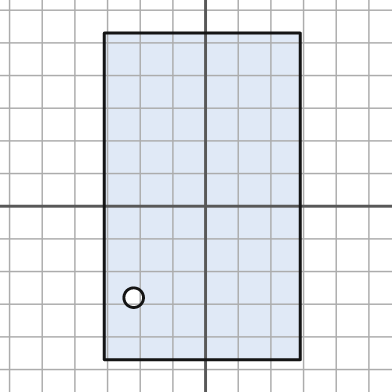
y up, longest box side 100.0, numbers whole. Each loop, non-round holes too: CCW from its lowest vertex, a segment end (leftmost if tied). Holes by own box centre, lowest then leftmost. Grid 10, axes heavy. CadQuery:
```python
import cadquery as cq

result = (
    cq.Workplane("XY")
    .moveTo(-31.0, -47.0)
    .lineTo(29.0, -47.0)
    .lineTo(29.0, 53.0)
    .lineTo(-31.0, 53.0)
    .close()
    .moveTo(-22.0, -28.0)
    .circle(3.0)
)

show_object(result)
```